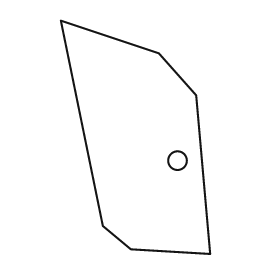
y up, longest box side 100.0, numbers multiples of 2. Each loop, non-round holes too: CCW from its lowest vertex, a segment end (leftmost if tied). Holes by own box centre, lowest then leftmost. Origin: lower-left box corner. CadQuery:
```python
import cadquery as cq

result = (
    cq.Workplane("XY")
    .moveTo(64.0, 0.0)
    .lineTo(58.0, 68.0)
    .lineTo(42.0, 86.0)
    .lineTo(0.0, 100.0)
    .lineTo(18.0, 12.0)
    .lineTo(30.0, 2.0)
    .close()
    .moveTo(50.0, 40.0)
    .circle(4.0)
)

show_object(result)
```